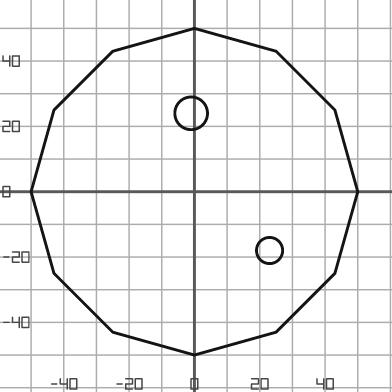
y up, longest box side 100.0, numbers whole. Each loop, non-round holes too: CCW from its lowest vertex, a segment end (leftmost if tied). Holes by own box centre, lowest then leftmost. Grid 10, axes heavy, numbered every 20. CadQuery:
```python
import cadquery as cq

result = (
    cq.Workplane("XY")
    .moveTo(0.0, -50.0)
    .lineTo(25.0, -43.0)
    .lineTo(43.0, -25.0)
    .lineTo(50.0, 0.0)
    .lineTo(43.0, 25.0)
    .lineTo(25.0, 43.0)
    .lineTo(0.0, 50.0)
    .lineTo(-25.0, 43.0)
    .lineTo(-43.0, 25.0)
    .lineTo(-50.0, 0.0)
    .lineTo(-43.0, -25.0)
    .lineTo(-25.0, -43.0)
    .close()
    .moveTo(23.0, -18.0)
    .circle(4.0)
    .moveTo(-1.0, 24.0)
    .circle(5.0)
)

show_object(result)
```